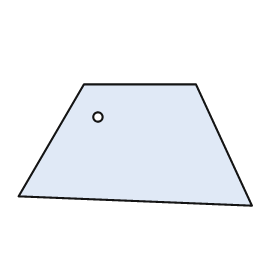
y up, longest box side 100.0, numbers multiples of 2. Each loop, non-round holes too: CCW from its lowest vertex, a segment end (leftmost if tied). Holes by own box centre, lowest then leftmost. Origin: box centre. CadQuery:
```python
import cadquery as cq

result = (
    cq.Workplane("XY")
    .moveTo(50.0, -26.0)
    .lineTo(26.0, 26.0)
    .lineTo(-22.0, 26.0)
    .lineTo(-50.0, -22.0)
    .close()
    .moveTo(-16.0, 12.0)
    .circle(2.0)
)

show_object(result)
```